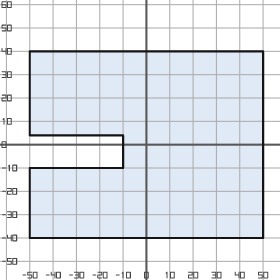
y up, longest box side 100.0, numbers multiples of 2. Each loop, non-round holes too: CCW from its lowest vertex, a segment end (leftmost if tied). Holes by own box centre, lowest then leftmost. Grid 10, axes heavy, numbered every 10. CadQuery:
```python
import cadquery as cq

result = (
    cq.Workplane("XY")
    .moveTo(-50.0, -40.0)
    .lineTo(50.0, -40.0)
    .lineTo(50.0, 40.0)
    .lineTo(-50.0, 40.0)
    .lineTo(-50.0, 4.0)
    .lineTo(-10.0, 4.0)
    .lineTo(-10.0, -10.0)
    .lineTo(-50.0, -10.0)
    .close()
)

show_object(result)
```